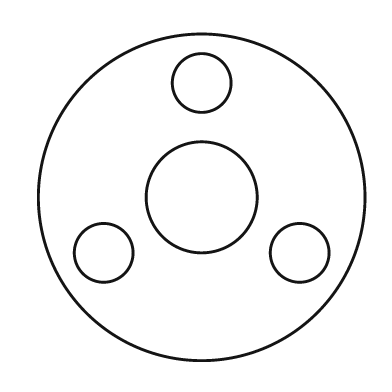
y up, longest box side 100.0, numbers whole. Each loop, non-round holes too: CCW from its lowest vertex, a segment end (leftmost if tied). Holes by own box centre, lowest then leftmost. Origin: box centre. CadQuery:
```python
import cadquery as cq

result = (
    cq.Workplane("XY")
    .moveTo(0.0, 0.0)
    .circle(50.0)
    .moveTo(-30.0, -17.0)
    .circle(9.0)
    .moveTo(30.0, -17.0)
    .circle(9.0)
    .moveTo(0.0, 0.0)
    .circle(17.0)
    .moveTo(0.0, 35.0)
    .circle(9.0)
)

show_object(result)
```